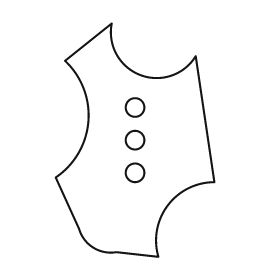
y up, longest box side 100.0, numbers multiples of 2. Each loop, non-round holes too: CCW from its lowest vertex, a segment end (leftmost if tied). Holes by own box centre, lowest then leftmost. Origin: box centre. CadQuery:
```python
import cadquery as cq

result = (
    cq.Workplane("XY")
    .moveTo(10.0, -50.0)
    .threePointArc((14.0, -28.0), (34.0, -18.0))
    .lineTo(26.0, 36.0)
    .threePointArc((2.0, 28.0), (-10.0, 50.0))
    .lineTo(-30.0, 34.0)
    .threePointArc((-20.0, 8.0), (-34.0, -16.0))
    .lineTo(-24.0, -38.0)
    .threePointArc((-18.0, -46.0), (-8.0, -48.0))
    .close()
    .moveTo(0.0, -14.0)
    .circle(4.0)
    .moveTo(0.0, 0.0)
    .circle(4.0)
    .moveTo(0.0, 14.0)
    .circle(4.0)
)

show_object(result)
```